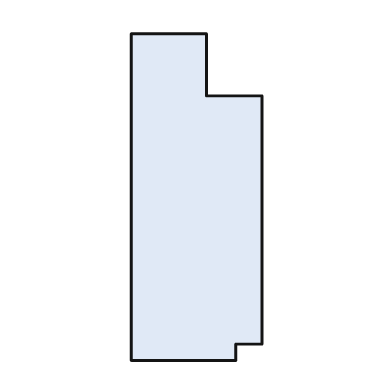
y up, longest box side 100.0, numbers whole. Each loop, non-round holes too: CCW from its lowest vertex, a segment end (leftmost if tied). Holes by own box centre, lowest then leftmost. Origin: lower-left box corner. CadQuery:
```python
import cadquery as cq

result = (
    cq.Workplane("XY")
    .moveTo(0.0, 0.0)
    .lineTo(32.0, 0.0)
    .lineTo(32.0, 5.0)
    .lineTo(40.0, 5.0)
    .lineTo(40.0, 81.0)
    .lineTo(23.0, 81.0)
    .lineTo(23.0, 100.0)
    .lineTo(0.0, 100.0)
    .close()
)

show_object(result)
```